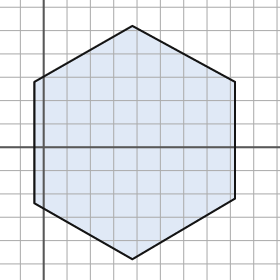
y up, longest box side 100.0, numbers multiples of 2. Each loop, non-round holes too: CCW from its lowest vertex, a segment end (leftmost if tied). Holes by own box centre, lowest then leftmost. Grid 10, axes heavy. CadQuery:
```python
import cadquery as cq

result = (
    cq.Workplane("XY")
    .moveTo(38.0, -48.0)
    .lineTo(82.0, -22.0)
    .lineTo(82.0, 28.0)
    .lineTo(38.0, 52.0)
    .lineTo(-4.0, 28.0)
    .lineTo(-4.0, -24.0)
    .close()
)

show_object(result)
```